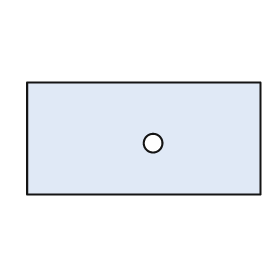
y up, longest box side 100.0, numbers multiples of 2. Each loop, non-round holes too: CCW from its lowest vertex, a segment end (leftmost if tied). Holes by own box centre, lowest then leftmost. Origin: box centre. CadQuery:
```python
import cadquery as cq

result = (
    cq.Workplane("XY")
    .moveTo(-50.0, -24.0)
    .lineTo(50.0, -24.0)
    .lineTo(50.0, 24.0)
    .lineTo(-50.0, 24.0)
    .close()
    .moveTo(4.0, -2.0)
    .circle(4.0)
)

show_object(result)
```